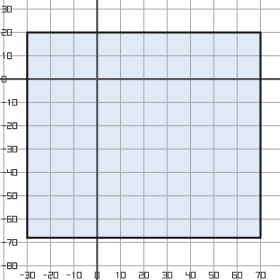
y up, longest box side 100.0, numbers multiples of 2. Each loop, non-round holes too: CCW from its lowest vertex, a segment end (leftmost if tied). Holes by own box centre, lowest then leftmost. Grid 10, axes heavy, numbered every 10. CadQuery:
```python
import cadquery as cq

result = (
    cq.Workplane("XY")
    .moveTo(-30.0, -68.0)
    .lineTo(70.0, -68.0)
    .lineTo(70.0, 20.0)
    .lineTo(-30.0, 20.0)
    .close()
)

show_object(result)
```